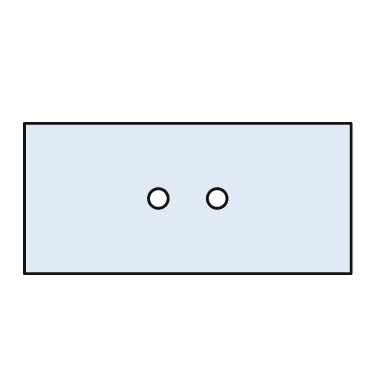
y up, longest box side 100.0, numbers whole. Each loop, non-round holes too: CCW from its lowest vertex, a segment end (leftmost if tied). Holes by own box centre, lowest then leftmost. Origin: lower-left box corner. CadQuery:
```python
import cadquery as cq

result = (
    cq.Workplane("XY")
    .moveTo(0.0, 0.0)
    .lineTo(100.0, 0.0)
    .lineTo(100.0, 46.0)
    .lineTo(0.0, 46.0)
    .close()
    .moveTo(41.0, 23.0)
    .circle(3.0)
    .moveTo(59.0, 23.0)
    .circle(3.0)
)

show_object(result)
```